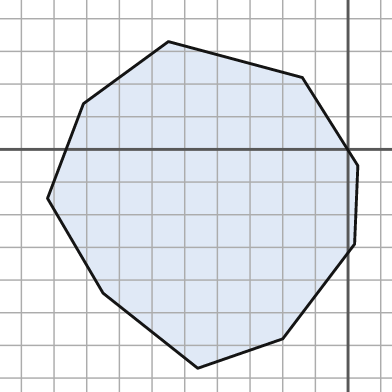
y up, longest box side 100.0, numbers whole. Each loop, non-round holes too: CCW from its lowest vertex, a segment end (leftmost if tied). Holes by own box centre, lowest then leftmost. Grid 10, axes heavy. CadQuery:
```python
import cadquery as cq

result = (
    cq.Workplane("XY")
    .moveTo(-46.0, -67.0)
    .lineTo(-20.0, -58.0)
    .lineTo(2.0, -29.0)
    .lineTo(3.0, -5.0)
    .lineTo(-14.0, 22.0)
    .lineTo(-55.0, 33.0)
    .lineTo(-81.0, 14.0)
    .lineTo(-92.0, -15.0)
    .lineTo(-75.0, -44.0)
    .close()
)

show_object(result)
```